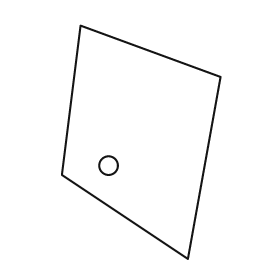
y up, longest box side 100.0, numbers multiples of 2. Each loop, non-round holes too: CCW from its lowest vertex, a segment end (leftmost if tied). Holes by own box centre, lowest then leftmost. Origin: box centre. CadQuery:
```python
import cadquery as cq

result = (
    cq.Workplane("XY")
    .moveTo(20.0, -50.0)
    .lineTo(34.0, 28.0)
    .lineTo(-26.0, 50.0)
    .lineTo(-34.0, -14.0)
    .close()
    .moveTo(-14.0, -10.0)
    .circle(4.0)
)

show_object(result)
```